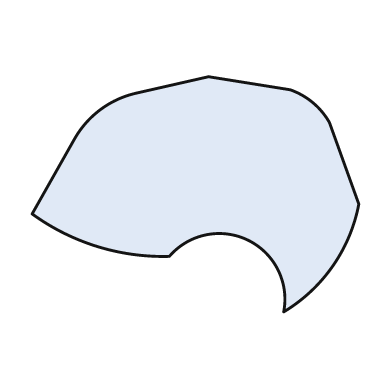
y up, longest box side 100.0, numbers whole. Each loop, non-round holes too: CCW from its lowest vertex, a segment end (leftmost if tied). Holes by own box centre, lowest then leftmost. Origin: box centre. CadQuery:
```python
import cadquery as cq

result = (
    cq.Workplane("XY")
    .moveTo(27.0, -36.0)
    .threePointArc((42.0, -22.0), (50.0, -3.0))
    .lineTo(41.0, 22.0)
    .threePointArc((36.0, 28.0), (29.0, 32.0))
    .lineTo(4.0, 36.0)
    .lineTo(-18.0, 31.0)
    .threePointArc((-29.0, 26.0), (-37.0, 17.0))
    .lineTo(-50.0, -6.0)
    .threePointArc((-30.0, -16.0), (-8.0, -19.0))
    .threePointArc((16.0, -14.0), (27.0, -36.0))
    .close()
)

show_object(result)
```